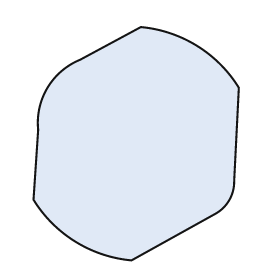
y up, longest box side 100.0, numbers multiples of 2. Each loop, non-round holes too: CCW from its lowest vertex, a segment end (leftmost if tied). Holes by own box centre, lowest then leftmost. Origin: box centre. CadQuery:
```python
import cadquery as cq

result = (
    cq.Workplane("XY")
    .moveTo(-2.0, -50.0)
    .lineTo(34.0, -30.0)
    .threePointArc((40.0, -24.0), (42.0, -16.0))
    .lineTo(44.0, 24.0)
    .threePointArc((26.0, 42.0), (2.0, 50.0))
    .lineTo(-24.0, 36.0)
    .threePointArc((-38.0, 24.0), (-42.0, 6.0))
    .lineTo(-44.0, -24.0)
    .threePointArc((-26.0, -42.0), (-2.0, -50.0))
    .close()
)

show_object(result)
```